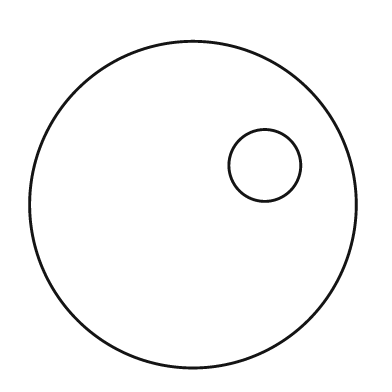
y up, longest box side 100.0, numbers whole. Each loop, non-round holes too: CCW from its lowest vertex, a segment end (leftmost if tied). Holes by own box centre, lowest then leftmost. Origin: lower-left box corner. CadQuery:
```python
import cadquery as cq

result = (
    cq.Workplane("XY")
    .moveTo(50.0, 50.0)
    .circle(50.0)
    .moveTo(72.0, 62.0)
    .circle(11.0)
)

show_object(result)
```